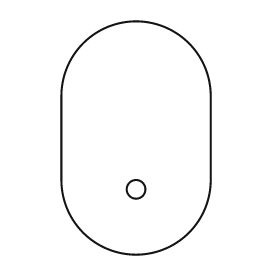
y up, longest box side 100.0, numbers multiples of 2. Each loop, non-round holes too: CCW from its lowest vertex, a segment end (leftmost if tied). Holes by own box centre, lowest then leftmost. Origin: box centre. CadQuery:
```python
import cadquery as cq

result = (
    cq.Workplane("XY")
    .moveTo(-32.0, -18.0)
    .threePointArc((0.0, -50.0), (32.0, -18.0))
    .lineTo(32.0, 18.0)
    .threePointArc((0.0, 50.0), (-32.0, 18.0))
    .close()
    .moveTo(0.0, -22.0)
    .circle(4.0)
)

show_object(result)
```